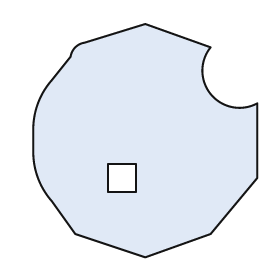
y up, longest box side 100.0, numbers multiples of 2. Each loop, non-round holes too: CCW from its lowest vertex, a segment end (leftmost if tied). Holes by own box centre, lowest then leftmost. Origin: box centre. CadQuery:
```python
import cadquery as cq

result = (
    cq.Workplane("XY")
    .moveTo(0.0, -50.0)
    .lineTo(28.0, -40.0)
    .lineTo(48.0, -16.0)
    .lineTo(48.0, 16.0)
    .threePointArc((28.0, 20.0), (28.0, 40.0))
    .lineTo(0.0, 50.0)
    .lineTo(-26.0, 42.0)
    .threePointArc((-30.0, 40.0), (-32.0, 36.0))
    .lineTo(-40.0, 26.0)
    .threePointArc((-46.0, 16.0), (-48.0, 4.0))
    .lineTo(-48.0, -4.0)
    .threePointArc((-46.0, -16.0), (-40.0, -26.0))
    .lineTo(-30.0, -40.0)
    .close()
    .moveTo(-16.0, -22.0)
    .lineTo(-4.0, -22.0)
    .lineTo(-4.0, -10.0)
    .lineTo(-16.0, -10.0)
    .close()
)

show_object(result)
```